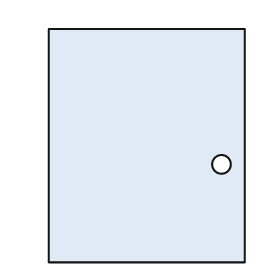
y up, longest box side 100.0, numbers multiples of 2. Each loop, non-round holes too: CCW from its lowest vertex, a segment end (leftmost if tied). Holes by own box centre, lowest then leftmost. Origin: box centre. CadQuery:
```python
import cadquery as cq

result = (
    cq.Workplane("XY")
    .moveTo(-42.0, -50.0)
    .lineTo(42.0, -50.0)
    .lineTo(42.0, 50.0)
    .lineTo(-42.0, 50.0)
    .close()
    .moveTo(32.0, -8.0)
    .circle(4.0)
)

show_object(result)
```